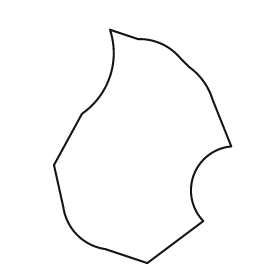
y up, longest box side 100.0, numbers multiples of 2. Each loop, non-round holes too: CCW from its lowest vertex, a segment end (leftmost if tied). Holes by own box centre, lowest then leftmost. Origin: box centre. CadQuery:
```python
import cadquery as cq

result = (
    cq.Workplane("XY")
    .moveTo(2.0, -50.0)
    .lineTo(26.0, -32.0)
    .threePointArc((22.0, -12.0), (38.0, 0.0))
    .lineTo(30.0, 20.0)
    .threePointArc((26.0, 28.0), (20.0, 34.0))
    .lineTo(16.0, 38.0)
    .threePointArc((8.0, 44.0), (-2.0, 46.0))
    .lineTo(-14.0, 50.0)
    .threePointArc((-14.0, 30.0), (-26.0, 14.0))
    .lineTo(-38.0, -8.0)
    .lineTo(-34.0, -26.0)
    .threePointArc((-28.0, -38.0), (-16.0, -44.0))
    .close()
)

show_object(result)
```